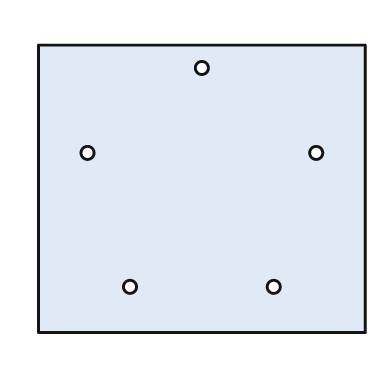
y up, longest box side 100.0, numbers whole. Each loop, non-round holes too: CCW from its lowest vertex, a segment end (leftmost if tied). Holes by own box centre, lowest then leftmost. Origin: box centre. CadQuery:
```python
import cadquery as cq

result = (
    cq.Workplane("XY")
    .moveTo(-50.0, -44.0)
    .lineTo(50.0, -44.0)
    .lineTo(50.0, 44.0)
    .lineTo(-50.0, 44.0)
    .close()
    .moveTo(-22.0, -30.0)
    .circle(2.0)
    .moveTo(22.0, -30.0)
    .circle(2.0)
    .moveTo(-35.0, 11.0)
    .circle(2.0)
    .moveTo(35.0, 11.0)
    .circle(2.0)
    .moveTo(0.0, 37.0)
    .circle(2.0)
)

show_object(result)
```